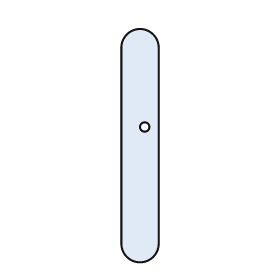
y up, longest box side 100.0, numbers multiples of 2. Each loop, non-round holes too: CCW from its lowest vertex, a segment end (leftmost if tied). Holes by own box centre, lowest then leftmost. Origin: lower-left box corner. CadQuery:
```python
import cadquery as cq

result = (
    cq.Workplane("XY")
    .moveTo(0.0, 8.0)
    .threePointArc((8.0, 0.0), (16.0, 8.0))
    .lineTo(16.0, 92.0)
    .threePointArc((8.0, 100.0), (0.0, 92.0))
    .close()
    .moveTo(10.0, 58.0)
    .circle(2.0)
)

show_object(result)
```